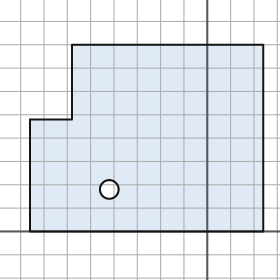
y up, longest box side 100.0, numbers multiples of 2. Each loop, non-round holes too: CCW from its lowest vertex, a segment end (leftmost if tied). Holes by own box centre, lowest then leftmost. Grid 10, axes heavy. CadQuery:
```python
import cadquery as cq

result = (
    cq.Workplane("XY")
    .moveTo(-76.0, 0.0)
    .lineTo(24.0, 0.0)
    .lineTo(24.0, 80.0)
    .lineTo(-58.0, 80.0)
    .lineTo(-58.0, 48.0)
    .lineTo(-76.0, 48.0)
    .close()
    .moveTo(-42.0, 18.0)
    .circle(4.0)
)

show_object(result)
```